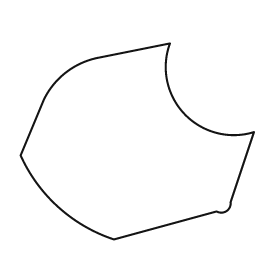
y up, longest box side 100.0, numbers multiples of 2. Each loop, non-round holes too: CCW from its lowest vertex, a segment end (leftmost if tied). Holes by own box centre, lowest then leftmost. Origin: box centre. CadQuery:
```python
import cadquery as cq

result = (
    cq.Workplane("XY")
    .moveTo(-10.0, -42.0)
    .lineTo(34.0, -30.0)
    .threePointArc((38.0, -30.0), (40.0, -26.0))
    .lineTo(50.0, 4.0)
    .threePointArc((20.0, 12.0), (14.0, 42.0))
    .lineTo(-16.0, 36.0)
    .threePointArc((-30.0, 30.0), (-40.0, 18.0))
    .lineTo(-50.0, -6.0)
    .threePointArc((-34.0, -28.0), (-10.0, -42.0))
    .close()
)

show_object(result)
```